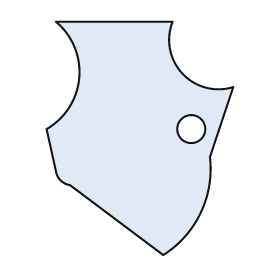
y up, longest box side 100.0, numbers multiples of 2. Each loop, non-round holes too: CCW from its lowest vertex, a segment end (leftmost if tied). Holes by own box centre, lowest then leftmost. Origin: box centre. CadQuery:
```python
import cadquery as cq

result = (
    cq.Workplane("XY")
    .moveTo(10.0, -50.0)
    .threePointArc((26.0, -32.0), (30.0, -8.0))
    .lineTo(40.0, 22.0)
    .threePointArc((18.0, 28.0), (14.0, 50.0))
    .lineTo(-36.0, 50.0)
    .threePointArc((-26.0, 26.0), (-40.0, 4.0))
    .lineTo(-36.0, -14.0)
    .threePointArc((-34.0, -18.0), (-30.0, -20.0))
    .close()
    .moveTo(22.0, 4.0)
    .circle(6.0)
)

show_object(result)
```